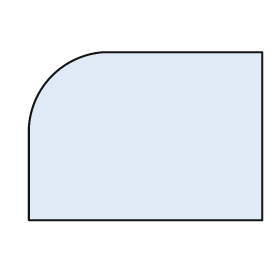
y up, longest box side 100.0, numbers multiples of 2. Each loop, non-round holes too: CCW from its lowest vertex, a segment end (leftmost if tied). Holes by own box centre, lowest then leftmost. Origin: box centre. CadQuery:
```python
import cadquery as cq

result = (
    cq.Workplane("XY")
    .moveTo(-50.0, -36.0)
    .lineTo(50.0, -36.0)
    .lineTo(50.0, 36.0)
    .lineTo(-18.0, 36.0)
    .threePointArc((-40.0, 26.0), (-50.0, 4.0))
    .close()
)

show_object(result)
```